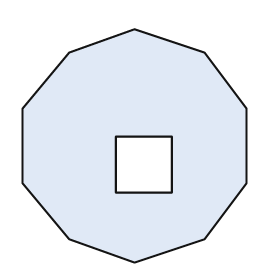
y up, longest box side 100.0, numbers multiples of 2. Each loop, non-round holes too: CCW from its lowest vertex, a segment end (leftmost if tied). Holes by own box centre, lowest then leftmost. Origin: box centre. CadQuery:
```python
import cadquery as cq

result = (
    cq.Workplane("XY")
    .moveTo(0.0, -50.0)
    .lineTo(30.0, -40.0)
    .lineTo(48.0, -16.0)
    .lineTo(48.0, 16.0)
    .lineTo(30.0, 40.0)
    .lineTo(0.0, 50.0)
    .lineTo(-28.0, 40.0)
    .lineTo(-48.0, 16.0)
    .lineTo(-48.0, -16.0)
    .lineTo(-28.0, -40.0)
    .close()
    .moveTo(-8.0, -20.0)
    .lineTo(16.0, -20.0)
    .lineTo(16.0, 4.0)
    .lineTo(-8.0, 4.0)
    .close()
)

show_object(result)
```